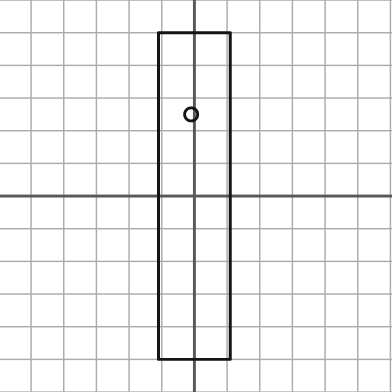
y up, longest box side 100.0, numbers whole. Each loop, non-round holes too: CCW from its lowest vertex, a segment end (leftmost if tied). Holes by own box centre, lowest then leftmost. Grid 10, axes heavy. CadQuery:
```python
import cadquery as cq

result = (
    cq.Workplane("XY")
    .moveTo(-11.0, -50.0)
    .lineTo(11.0, -50.0)
    .lineTo(11.0, 50.0)
    .lineTo(-11.0, 50.0)
    .close()
    .moveTo(-1.0, 25.0)
    .circle(2.0)
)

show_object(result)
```